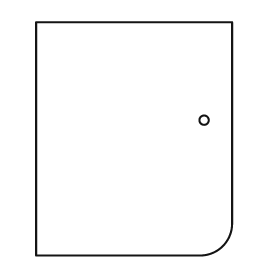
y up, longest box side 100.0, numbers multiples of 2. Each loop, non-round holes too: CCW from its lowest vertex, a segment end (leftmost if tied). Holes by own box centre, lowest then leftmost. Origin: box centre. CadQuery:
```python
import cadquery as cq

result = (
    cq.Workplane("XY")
    .moveTo(-42.0, -50.0)
    .lineTo(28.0, -50.0)
    .threePointArc((38.0, -46.0), (42.0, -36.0))
    .lineTo(42.0, 50.0)
    .lineTo(-42.0, 50.0)
    .close()
    .moveTo(30.0, 8.0)
    .circle(2.0)
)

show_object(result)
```